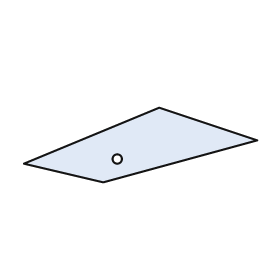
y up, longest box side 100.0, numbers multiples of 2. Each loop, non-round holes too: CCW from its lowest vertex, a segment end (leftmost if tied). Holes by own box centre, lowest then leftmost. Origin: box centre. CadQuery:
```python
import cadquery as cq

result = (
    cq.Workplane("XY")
    .moveTo(-16.0, -16.0)
    .lineTo(50.0, 2.0)
    .lineTo(8.0, 16.0)
    .lineTo(-50.0, -8.0)
    .close()
    .moveTo(-10.0, -6.0)
    .circle(2.0)
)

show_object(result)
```